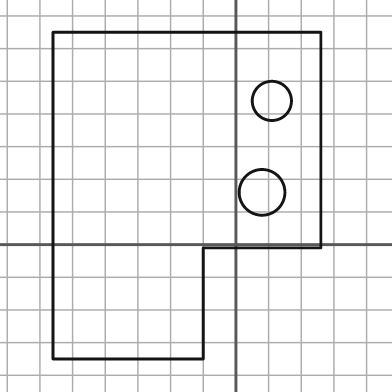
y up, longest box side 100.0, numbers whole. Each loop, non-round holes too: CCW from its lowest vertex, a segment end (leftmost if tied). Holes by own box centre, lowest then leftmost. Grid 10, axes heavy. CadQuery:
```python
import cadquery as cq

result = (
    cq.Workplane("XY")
    .moveTo(-56.0, -35.0)
    .lineTo(-10.0, -35.0)
    .lineTo(-10.0, -1.0)
    .lineTo(26.0, -1.0)
    .lineTo(26.0, 65.0)
    .lineTo(-56.0, 65.0)
    .close()
    .moveTo(8.0, 16.0)
    .circle(7.0)
    .moveTo(11.0, 44.0)
    .circle(6.0)
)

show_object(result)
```